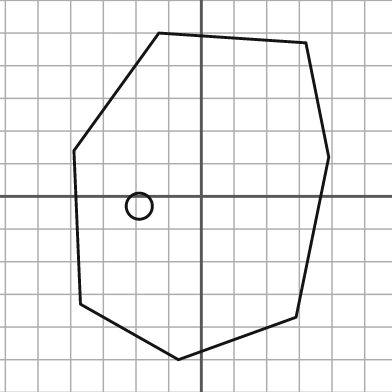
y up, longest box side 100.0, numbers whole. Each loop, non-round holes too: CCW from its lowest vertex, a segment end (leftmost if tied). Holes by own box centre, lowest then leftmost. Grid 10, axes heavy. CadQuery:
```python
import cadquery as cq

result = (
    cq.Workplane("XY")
    .moveTo(-7.0, -50.0)
    .lineTo(29.0, -37.0)
    .lineTo(39.0, 12.0)
    .lineTo(32.0, 47.0)
    .lineTo(-13.0, 50.0)
    .lineTo(-39.0, 14.0)
    .lineTo(-37.0, -33.0)
    .close()
    .moveTo(-19.0, -3.0)
    .circle(4.0)
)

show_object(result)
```